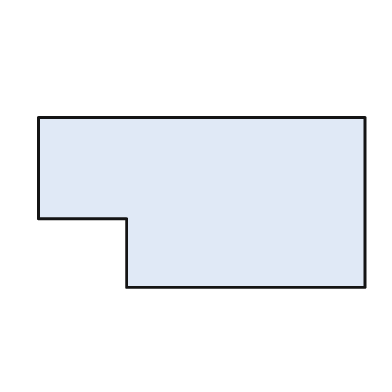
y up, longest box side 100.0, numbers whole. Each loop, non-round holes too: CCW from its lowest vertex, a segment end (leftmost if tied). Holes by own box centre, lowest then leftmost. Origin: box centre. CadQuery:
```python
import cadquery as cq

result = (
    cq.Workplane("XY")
    .moveTo(-23.0, -26.0)
    .lineTo(50.0, -26.0)
    .lineTo(50.0, 26.0)
    .lineTo(-50.0, 26.0)
    .lineTo(-50.0, -5.0)
    .lineTo(-23.0, -5.0)
    .close()
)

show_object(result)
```